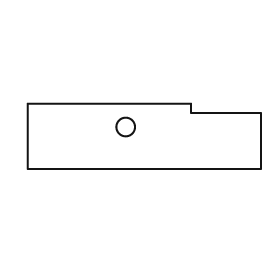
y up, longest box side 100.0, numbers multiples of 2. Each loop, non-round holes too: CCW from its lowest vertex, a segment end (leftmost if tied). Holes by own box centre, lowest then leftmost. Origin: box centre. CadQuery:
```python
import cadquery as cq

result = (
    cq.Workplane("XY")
    .moveTo(-50.0, -14.0)
    .lineTo(50.0, -14.0)
    .lineTo(50.0, 10.0)
    .lineTo(20.0, 10.0)
    .lineTo(20.0, 14.0)
    .lineTo(-50.0, 14.0)
    .close()
    .moveTo(-8.0, 4.0)
    .circle(4.0)
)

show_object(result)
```